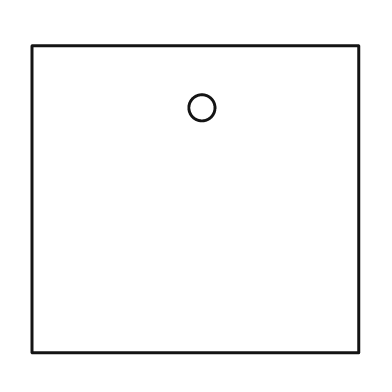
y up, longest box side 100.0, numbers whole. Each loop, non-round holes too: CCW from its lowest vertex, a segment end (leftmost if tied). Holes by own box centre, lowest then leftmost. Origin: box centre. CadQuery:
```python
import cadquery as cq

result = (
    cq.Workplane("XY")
    .moveTo(-50.0, -47.0)
    .lineTo(50.0, -47.0)
    .lineTo(50.0, 47.0)
    .lineTo(-50.0, 47.0)
    .close()
    .moveTo(2.0, 28.0)
    .circle(4.0)
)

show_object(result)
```